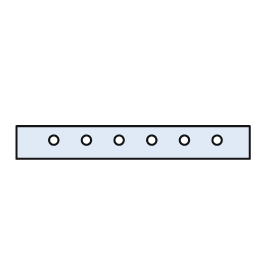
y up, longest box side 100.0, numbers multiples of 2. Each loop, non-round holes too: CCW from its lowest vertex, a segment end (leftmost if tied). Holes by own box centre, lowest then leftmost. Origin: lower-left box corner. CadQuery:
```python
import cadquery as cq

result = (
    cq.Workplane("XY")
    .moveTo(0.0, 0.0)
    .lineTo(100.0, 0.0)
    .lineTo(100.0, 14.0)
    .lineTo(0.0, 14.0)
    .close()
    .moveTo(16.0, 8.0)
    .circle(2.0)
    .moveTo(30.0, 8.0)
    .circle(2.0)
    .moveTo(44.0, 8.0)
    .circle(2.0)
    .moveTo(58.0, 8.0)
    .circle(2.0)
    .moveTo(72.0, 8.0)
    .circle(2.0)
    .moveTo(86.0, 8.0)
    .circle(2.0)
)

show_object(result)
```